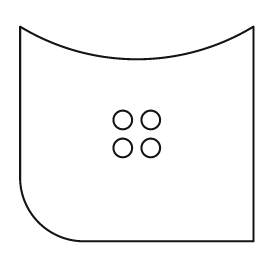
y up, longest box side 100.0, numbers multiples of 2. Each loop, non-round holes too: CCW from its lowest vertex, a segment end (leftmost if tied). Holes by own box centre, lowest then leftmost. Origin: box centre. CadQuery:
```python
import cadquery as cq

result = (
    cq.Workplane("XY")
    .moveTo(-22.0, -46.0)
    .lineTo(50.0, -46.0)
    .lineTo(50.0, 46.0)
    .threePointArc((0.0, 32.0), (-50.0, 46.0))
    .lineTo(-50.0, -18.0)
    .threePointArc((-42.0, -38.0), (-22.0, -46.0))
    .close()
    .moveTo(-6.0, -6.0)
    .circle(4.0)
    .moveTo(6.0, -6.0)
    .circle(4.0)
    .moveTo(-6.0, 6.0)
    .circle(4.0)
    .moveTo(6.0, 6.0)
    .circle(4.0)
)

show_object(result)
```